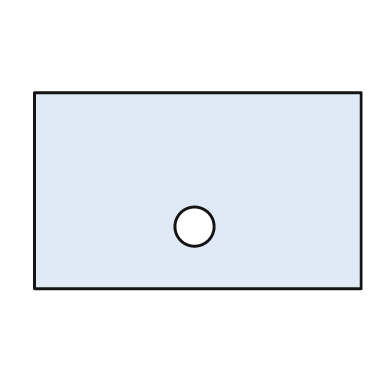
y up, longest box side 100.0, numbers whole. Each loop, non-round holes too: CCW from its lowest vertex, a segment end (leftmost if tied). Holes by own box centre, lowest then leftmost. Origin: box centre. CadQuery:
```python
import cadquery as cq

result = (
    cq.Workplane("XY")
    .moveTo(-50.0, -30.0)
    .lineTo(50.0, -30.0)
    .lineTo(50.0, 30.0)
    .lineTo(-50.0, 30.0)
    .close()
    .moveTo(-1.0, -11.0)
    .circle(6.0)
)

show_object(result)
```